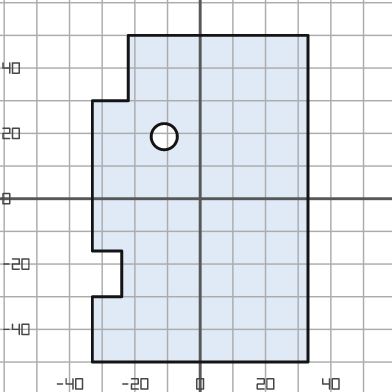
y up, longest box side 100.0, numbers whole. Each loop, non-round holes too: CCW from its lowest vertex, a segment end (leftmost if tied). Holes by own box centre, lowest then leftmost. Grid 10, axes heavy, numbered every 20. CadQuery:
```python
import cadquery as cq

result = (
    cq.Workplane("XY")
    .moveTo(-33.0, -50.0)
    .lineTo(33.0, -50.0)
    .lineTo(33.0, 50.0)
    .lineTo(-22.0, 50.0)
    .lineTo(-22.0, 30.0)
    .lineTo(-33.0, 30.0)
    .lineTo(-33.0, -16.0)
    .lineTo(-24.0, -16.0)
    .lineTo(-24.0, -30.0)
    .lineTo(-33.0, -30.0)
    .close()
    .moveTo(-11.0, 19.0)
    .circle(4.0)
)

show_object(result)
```